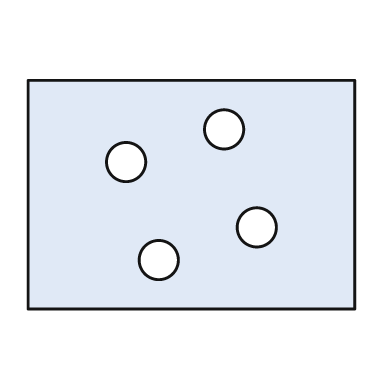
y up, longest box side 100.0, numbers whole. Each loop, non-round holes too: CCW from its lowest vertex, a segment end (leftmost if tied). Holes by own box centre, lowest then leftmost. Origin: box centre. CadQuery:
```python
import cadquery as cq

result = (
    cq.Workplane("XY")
    .moveTo(-50.0, -35.0)
    .lineTo(50.0, -35.0)
    .lineTo(50.0, 35.0)
    .lineTo(-50.0, 35.0)
    .close()
    .moveTo(-10.0, -20.0)
    .circle(6.0)
    .moveTo(20.0, -10.0)
    .circle(6.0)
    .moveTo(-20.0, 10.0)
    .circle(6.0)
    .moveTo(10.0, 20.0)
    .circle(6.0)
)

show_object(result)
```